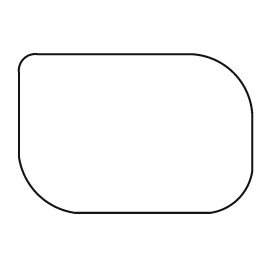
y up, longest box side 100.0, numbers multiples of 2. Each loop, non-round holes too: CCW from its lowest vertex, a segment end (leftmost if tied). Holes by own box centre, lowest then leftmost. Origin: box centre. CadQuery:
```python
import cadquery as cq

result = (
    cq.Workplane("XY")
    .moveTo(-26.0, -34.0)
    .lineTo(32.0, -34.0)
    .threePointArc((44.0, -28.0), (50.0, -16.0))
    .lineTo(50.0, 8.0)
    .threePointArc((42.0, 26.0), (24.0, 34.0))
    .lineTo(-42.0, 34.0)
    .threePointArc((-48.0, 32.0), (-50.0, 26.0))
    .lineTo(-50.0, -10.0)
    .threePointArc((-42.0, -26.0), (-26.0, -34.0))
    .close()
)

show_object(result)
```